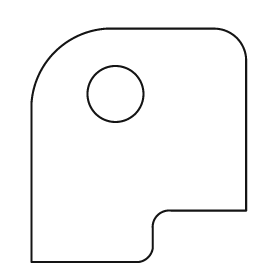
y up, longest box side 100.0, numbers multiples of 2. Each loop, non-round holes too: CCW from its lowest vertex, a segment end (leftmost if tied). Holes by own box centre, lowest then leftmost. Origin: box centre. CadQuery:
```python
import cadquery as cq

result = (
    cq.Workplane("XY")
    .moveTo(-46.0, -50.0)
    .lineTo(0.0, -50.0)
    .threePointArc((4.0, -48.0), (6.0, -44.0))
    .lineTo(6.0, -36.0)
    .threePointArc((8.0, -30.0), (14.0, -28.0))
    .lineTo(46.0, -28.0)
    .lineTo(46.0, 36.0)
    .threePointArc((42.0, 46.0), (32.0, 50.0))
    .lineTo(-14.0, 50.0)
    .threePointArc((-36.0, 40.0), (-46.0, 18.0))
    .close()
    .moveTo(-10.0, 22.0)
    .circle(12.0)
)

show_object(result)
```